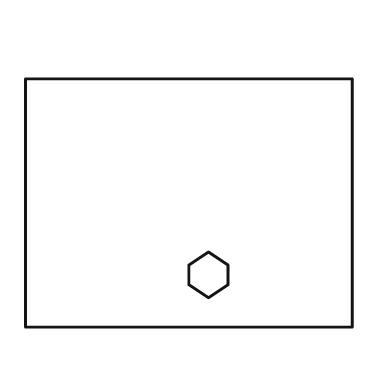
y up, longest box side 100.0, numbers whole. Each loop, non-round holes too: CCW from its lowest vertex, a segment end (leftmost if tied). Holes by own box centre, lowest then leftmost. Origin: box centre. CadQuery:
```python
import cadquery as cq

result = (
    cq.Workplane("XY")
    .moveTo(-50.0, -38.0)
    .lineTo(50.0, -38.0)
    .lineTo(50.0, 38.0)
    .lineTo(-50.0, 38.0)
    .close()
    .moveTo(6.0, -29.0)
    .lineTo(12.0, -25.0)
    .lineTo(12.0, -19.0)
    .lineTo(6.0, -15.0)
    .lineTo(0.0, -19.0)
    .lineTo(0.0, -25.0)
    .close()
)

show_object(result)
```